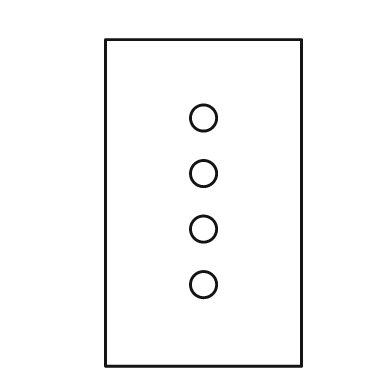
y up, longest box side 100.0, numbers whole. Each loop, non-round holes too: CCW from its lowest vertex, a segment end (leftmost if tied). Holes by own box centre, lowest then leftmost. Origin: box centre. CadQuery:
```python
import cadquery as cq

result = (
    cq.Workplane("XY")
    .moveTo(-30.0, -50.0)
    .lineTo(30.0, -50.0)
    .lineTo(30.0, 50.0)
    .lineTo(-30.0, 50.0)
    .close()
    .moveTo(0.0, -25.0)
    .circle(4.0)
    .moveTo(0.0, -8.0)
    .circle(4.0)
    .moveTo(0.0, 9.0)
    .circle(4.0)
    .moveTo(0.0, 26.0)
    .circle(4.0)
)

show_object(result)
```